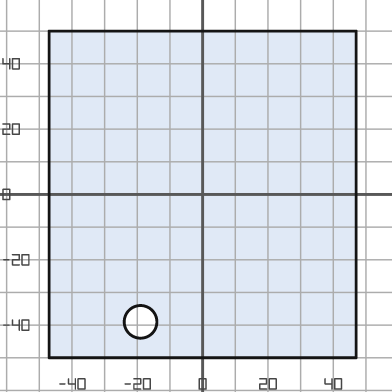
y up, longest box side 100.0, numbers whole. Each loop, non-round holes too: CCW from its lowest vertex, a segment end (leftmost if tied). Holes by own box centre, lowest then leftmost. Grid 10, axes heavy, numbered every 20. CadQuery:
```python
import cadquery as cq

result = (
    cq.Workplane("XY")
    .moveTo(-47.0, -50.0)
    .lineTo(47.0, -50.0)
    .lineTo(47.0, 50.0)
    .lineTo(-47.0, 50.0)
    .close()
    .moveTo(-19.0, -39.0)
    .circle(5.0)
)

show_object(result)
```